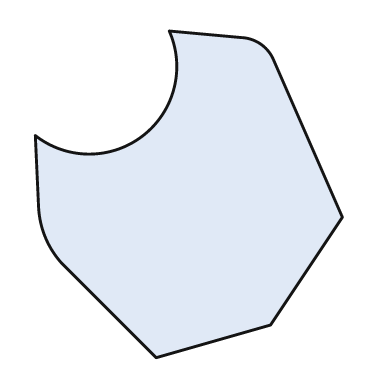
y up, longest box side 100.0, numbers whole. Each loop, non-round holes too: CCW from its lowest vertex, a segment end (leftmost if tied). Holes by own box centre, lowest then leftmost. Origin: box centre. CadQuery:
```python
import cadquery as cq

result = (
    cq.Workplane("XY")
    .moveTo(-10.0, -50.0)
    .lineTo(25.0, -40.0)
    .lineTo(47.0, -7.0)
    .lineTo(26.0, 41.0)
    .threePointArc((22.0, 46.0), (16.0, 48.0))
    .lineTo(-6.0, 50.0)
    .threePointArc((-14.0, 18.0), (-47.0, 18.0))
    .lineTo(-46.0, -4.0)
    .threePointArc((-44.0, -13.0), (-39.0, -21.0))
    .close()
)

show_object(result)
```